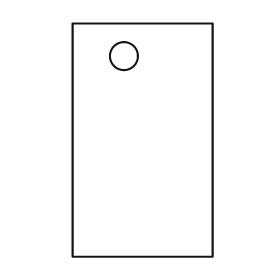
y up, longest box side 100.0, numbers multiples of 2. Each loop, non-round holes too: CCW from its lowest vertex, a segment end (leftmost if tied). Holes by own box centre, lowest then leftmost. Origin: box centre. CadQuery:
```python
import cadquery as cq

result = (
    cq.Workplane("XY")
    .moveTo(-30.0, -50.0)
    .lineTo(30.0, -50.0)
    .lineTo(30.0, 50.0)
    .lineTo(-30.0, 50.0)
    .close()
    .moveTo(-8.0, 36.0)
    .circle(6.0)
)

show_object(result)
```